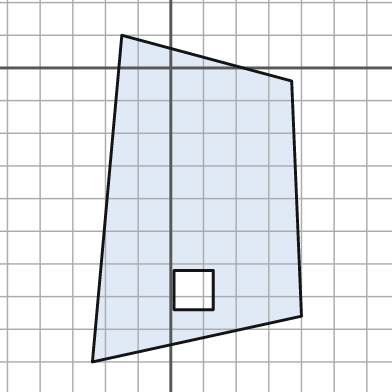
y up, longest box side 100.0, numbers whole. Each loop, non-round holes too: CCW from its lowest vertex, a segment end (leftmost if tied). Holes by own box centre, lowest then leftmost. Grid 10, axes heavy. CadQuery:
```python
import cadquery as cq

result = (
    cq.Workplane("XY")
    .moveTo(-24.0, -90.0)
    .lineTo(40.0, -76.0)
    .lineTo(37.0, -4.0)
    .lineTo(-15.0, 10.0)
    .close()
    .moveTo(1.0, -74.0)
    .lineTo(13.0, -74.0)
    .lineTo(13.0, -62.0)
    .lineTo(1.0, -62.0)
    .close()
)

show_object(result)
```